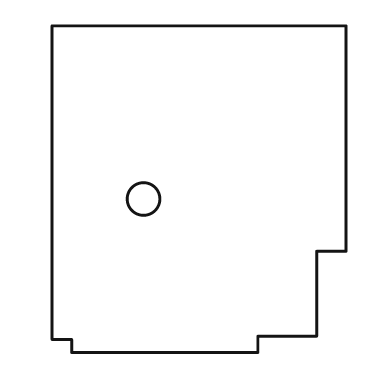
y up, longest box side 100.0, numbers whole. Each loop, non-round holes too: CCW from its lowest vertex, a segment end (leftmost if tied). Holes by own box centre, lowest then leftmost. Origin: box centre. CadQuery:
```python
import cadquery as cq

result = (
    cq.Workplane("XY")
    .moveTo(-39.0, -50.0)
    .lineTo(18.0, -50.0)
    .lineTo(18.0, -45.0)
    .lineTo(36.0, -45.0)
    .lineTo(36.0, -19.0)
    .lineTo(45.0, -19.0)
    .lineTo(45.0, 50.0)
    .lineTo(-45.0, 50.0)
    .lineTo(-45.0, -46.0)
    .lineTo(-39.0, -46.0)
    .close()
    .moveTo(-17.0, -3.0)
    .circle(5.0)
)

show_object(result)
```